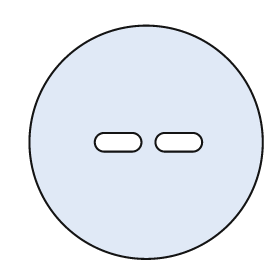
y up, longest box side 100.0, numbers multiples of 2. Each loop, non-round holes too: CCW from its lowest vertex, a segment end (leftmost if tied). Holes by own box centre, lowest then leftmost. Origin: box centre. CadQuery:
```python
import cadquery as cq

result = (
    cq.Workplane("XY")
    .moveTo(0.0, 0.0)
    .circle(50.0)
    .moveTo(-18.0, -4.0)
    .lineTo(-6.0, -4.0)
    .threePointArc((-2.0, 0.0), (-6.0, 4.0))
    .lineTo(-18.0, 4.0)
    .threePointArc((-22.0, 0.0), (-18.0, -4.0))
    .close()
    .moveTo(8.0, -4.0)
    .lineTo(20.0, -4.0)
    .threePointArc((24.0, 0.0), (20.0, 4.0))
    .lineTo(8.0, 4.0)
    .threePointArc((4.0, 0.0), (8.0, -4.0))
    .close()
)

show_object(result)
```